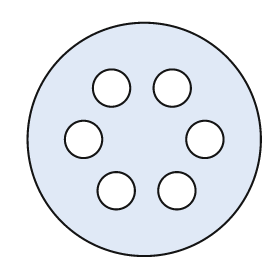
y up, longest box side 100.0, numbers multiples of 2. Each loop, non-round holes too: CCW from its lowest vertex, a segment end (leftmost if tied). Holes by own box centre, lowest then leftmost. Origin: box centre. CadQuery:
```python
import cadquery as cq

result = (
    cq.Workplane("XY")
    .moveTo(0.0, 0.0)
    .circle(50.0)
    .moveTo(-12.0, -22.0)
    .circle(8.0)
    .moveTo(14.0, -22.0)
    .circle(8.0)
    .moveTo(-26.0, 0.0)
    .circle(8.0)
    .moveTo(26.0, 0.0)
    .circle(8.0)
    .moveTo(-14.0, 22.0)
    .circle(8.0)
    .moveTo(12.0, 22.0)
    .circle(8.0)
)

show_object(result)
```